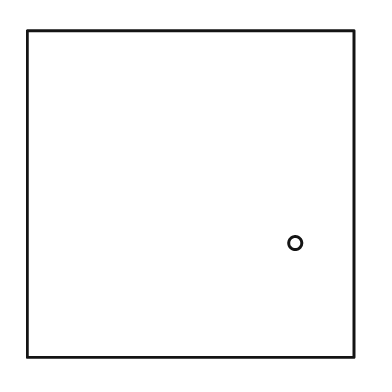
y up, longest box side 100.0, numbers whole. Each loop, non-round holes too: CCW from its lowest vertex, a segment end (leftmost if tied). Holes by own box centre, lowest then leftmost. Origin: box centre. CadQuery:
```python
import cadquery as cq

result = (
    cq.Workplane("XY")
    .moveTo(-50.0, -50.0)
    .lineTo(50.0, -50.0)
    .lineTo(50.0, 50.0)
    .lineTo(-50.0, 50.0)
    .close()
    .moveTo(32.0, -15.0)
    .circle(2.0)
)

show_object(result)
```